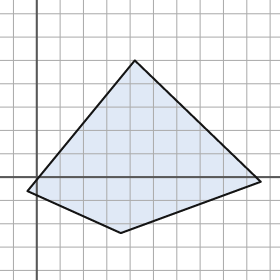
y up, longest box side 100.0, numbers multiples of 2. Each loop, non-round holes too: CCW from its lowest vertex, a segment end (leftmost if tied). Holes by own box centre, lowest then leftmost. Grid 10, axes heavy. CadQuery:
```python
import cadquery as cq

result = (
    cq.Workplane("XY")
    .moveTo(36.0, -24.0)
    .lineTo(96.0, -2.0)
    .lineTo(42.0, 50.0)
    .lineTo(-4.0, -6.0)
    .close()
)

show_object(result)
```